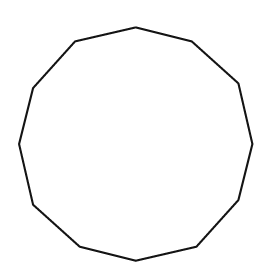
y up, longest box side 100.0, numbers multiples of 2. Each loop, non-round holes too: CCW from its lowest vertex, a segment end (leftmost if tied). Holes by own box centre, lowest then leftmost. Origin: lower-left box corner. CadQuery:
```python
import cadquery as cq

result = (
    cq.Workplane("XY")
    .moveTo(50.0, 0.0)
    .lineTo(76.0, 6.0)
    .lineTo(94.0, 26.0)
    .lineTo(100.0, 50.0)
    .lineTo(94.0, 76.0)
    .lineTo(74.0, 94.0)
    .lineTo(50.0, 100.0)
    .lineTo(24.0, 94.0)
    .lineTo(6.0, 74.0)
    .lineTo(0.0, 50.0)
    .lineTo(6.0, 24.0)
    .lineTo(26.0, 6.0)
    .close()
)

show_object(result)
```